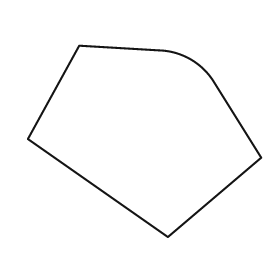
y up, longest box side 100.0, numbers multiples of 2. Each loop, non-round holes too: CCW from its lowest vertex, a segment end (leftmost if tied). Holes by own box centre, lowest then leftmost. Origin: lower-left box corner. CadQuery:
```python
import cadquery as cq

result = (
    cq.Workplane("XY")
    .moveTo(60.0, 0.0)
    .lineTo(100.0, 34.0)
    .lineTo(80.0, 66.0)
    .threePointArc((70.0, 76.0), (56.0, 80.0))
    .lineTo(22.0, 82.0)
    .lineTo(0.0, 42.0)
    .close()
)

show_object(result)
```